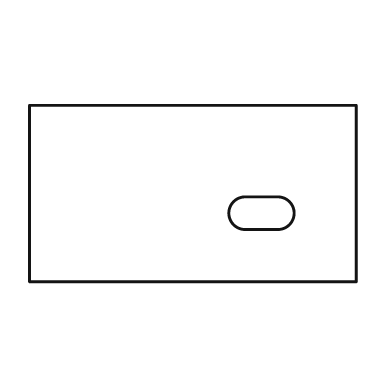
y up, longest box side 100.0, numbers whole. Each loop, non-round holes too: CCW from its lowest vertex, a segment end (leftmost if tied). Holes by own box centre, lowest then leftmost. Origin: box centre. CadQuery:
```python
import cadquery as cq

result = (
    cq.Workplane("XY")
    .moveTo(-50.0, -27.0)
    .lineTo(50.0, -27.0)
    .lineTo(50.0, 27.0)
    .lineTo(-50.0, 27.0)
    .close()
    .moveTo(16.0, -11.0)
    .lineTo(26.0, -11.0)
    .threePointArc((31.0, -6.0), (26.0, -1.0))
    .lineTo(16.0, -1.0)
    .threePointArc((11.0, -6.0), (16.0, -11.0))
    .close()
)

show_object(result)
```